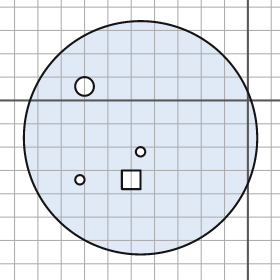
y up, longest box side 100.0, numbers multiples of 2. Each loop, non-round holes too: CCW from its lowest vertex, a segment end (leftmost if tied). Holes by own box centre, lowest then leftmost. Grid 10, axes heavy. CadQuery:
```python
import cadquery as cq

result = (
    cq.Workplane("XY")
    .moveTo(-46.0, -16.0)
    .circle(50.0)
    .moveTo(-72.0, -34.0)
    .circle(2.0)
    .moveTo(-54.0, -38.0)
    .lineTo(-46.0, -38.0)
    .lineTo(-46.0, -30.0)
    .lineTo(-54.0, -30.0)
    .close()
    .moveTo(-46.0, -22.0)
    .circle(2.0)
    .moveTo(-70.0, 6.0)
    .circle(4.0)
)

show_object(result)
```